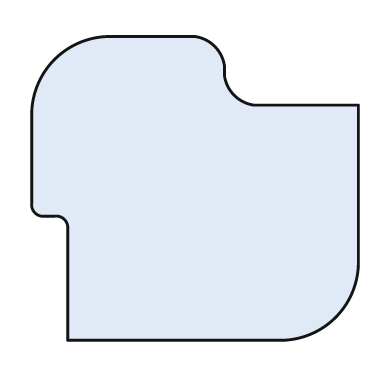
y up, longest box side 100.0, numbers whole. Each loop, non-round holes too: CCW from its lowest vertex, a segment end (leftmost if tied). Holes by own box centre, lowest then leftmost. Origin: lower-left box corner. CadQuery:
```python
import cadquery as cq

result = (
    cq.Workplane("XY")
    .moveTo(11.0, 0.0)
    .lineTo(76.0, 0.0)
    .threePointArc((93.0, 7.0), (100.0, 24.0))
    .lineTo(100.0, 72.0)
    .lineTo(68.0, 72.0)
    .threePointArc((62.0, 75.0), (59.0, 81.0))
    .lineTo(59.0, 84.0)
    .threePointArc((56.0, 90.0), (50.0, 93.0))
    .lineTo(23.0, 93.0)
    .threePointArc((7.0, 86.0), (0.0, 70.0))
    .lineTo(0.0, 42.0)
    .threePointArc((1.0, 39.0), (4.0, 38.0))
    .lineTo(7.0, 38.0)
    .threePointArc((10.0, 37.0), (11.0, 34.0))
    .close()
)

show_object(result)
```